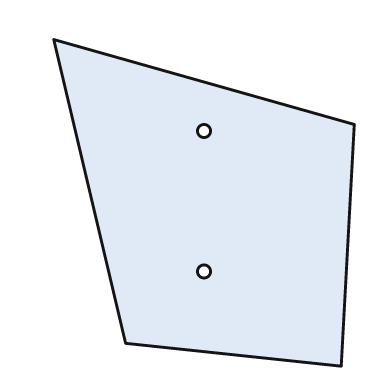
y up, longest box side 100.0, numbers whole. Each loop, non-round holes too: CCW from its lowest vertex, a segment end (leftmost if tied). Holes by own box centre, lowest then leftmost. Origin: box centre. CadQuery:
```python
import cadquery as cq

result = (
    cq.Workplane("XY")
    .moveTo(42.0, -50.0)
    .lineTo(46.0, 24.0)
    .lineTo(-46.0, 50.0)
    .lineTo(-24.0, -43.0)
    .close()
    .moveTo(0.0, -21.0)
    .circle(2.0)
    .moveTo(0.0, 22.0)
    .circle(2.0)
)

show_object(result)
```